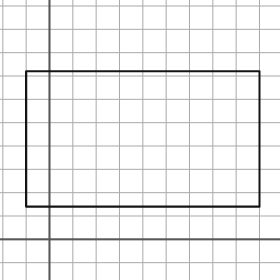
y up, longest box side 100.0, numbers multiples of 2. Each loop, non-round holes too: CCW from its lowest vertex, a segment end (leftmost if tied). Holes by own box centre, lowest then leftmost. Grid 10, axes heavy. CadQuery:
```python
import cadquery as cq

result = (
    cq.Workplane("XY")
    .moveTo(-10.0, 14.0)
    .lineTo(90.0, 14.0)
    .lineTo(90.0, 72.0)
    .lineTo(-10.0, 72.0)
    .close()
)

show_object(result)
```